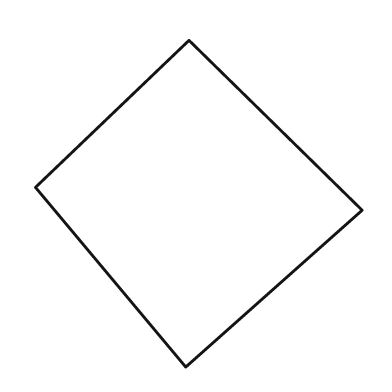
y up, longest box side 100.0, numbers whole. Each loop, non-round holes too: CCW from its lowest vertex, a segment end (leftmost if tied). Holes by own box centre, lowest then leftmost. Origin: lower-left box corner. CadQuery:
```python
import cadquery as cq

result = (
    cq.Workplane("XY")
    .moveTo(46.0, 0.0)
    .lineTo(100.0, 48.0)
    .lineTo(47.0, 100.0)
    .lineTo(0.0, 55.0)
    .close()
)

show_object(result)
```